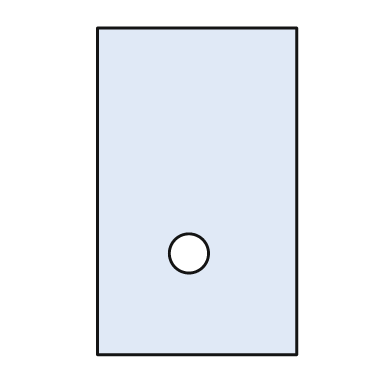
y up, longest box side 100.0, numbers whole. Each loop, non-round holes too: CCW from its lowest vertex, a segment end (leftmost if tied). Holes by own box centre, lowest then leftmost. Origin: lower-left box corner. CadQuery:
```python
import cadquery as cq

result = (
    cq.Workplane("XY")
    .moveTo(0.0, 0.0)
    .lineTo(61.0, 0.0)
    .lineTo(61.0, 100.0)
    .lineTo(0.0, 100.0)
    .close()
    .moveTo(28.0, 31.0)
    .circle(6.0)
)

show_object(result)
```